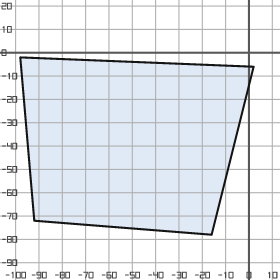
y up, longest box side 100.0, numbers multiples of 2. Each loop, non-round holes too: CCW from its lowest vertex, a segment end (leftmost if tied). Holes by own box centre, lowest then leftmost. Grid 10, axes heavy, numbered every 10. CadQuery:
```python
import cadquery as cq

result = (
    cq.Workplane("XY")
    .moveTo(-16.0, -78.0)
    .lineTo(2.0, -6.0)
    .lineTo(-98.0, -2.0)
    .lineTo(-92.0, -72.0)
    .close()
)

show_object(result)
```